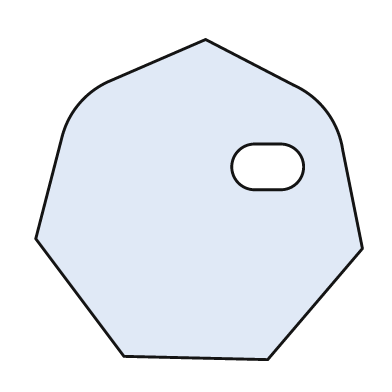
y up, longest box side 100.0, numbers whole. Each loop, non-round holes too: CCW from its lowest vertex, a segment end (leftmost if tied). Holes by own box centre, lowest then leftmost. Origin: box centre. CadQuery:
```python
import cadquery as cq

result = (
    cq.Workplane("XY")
    .moveTo(21.0, -49.0)
    .lineTo(50.0, -15.0)
    .lineTo(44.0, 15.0)
    .threePointArc((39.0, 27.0), (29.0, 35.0))
    .lineTo(2.0, 49.0)
    .lineTo(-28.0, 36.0)
    .threePointArc((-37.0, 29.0), (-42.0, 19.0))
    .lineTo(-50.0, -12.0)
    .lineTo(-23.0, -48.0)
    .close()
    .moveTo(17.0, 3.0)
    .lineTo(25.0, 3.0)
    .threePointArc((32.0, 10.0), (25.0, 17.0))
    .lineTo(17.0, 17.0)
    .threePointArc((10.0, 10.0), (17.0, 3.0))
    .close()
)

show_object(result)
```